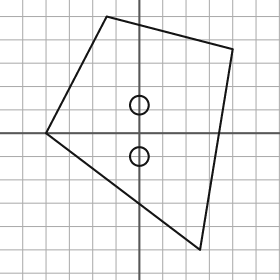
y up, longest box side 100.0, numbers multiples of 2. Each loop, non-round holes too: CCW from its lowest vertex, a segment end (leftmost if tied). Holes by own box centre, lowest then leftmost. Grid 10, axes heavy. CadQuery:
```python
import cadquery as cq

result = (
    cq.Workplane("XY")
    .moveTo(26.0, -50.0)
    .lineTo(40.0, 36.0)
    .lineTo(-14.0, 50.0)
    .lineTo(-40.0, 0.0)
    .close()
    .moveTo(0.0, -10.0)
    .circle(4.0)
    .moveTo(0.0, 12.0)
    .circle(4.0)
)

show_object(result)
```